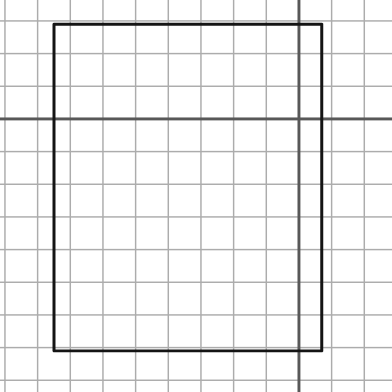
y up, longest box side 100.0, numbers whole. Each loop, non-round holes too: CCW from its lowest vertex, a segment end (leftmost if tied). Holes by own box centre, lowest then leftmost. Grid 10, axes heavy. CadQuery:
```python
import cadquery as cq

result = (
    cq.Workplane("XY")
    .moveTo(-75.0, -71.0)
    .lineTo(7.0, -71.0)
    .lineTo(7.0, 29.0)
    .lineTo(-75.0, 29.0)
    .close()
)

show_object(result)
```